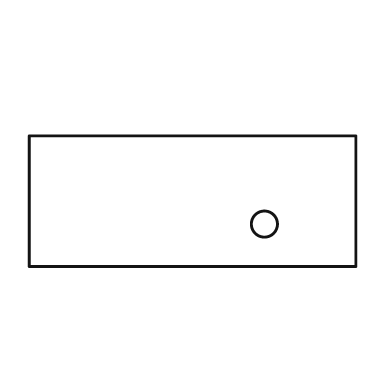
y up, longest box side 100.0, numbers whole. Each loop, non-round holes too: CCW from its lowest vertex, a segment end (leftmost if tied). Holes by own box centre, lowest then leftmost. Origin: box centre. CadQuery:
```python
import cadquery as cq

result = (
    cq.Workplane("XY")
    .moveTo(-50.0, -20.0)
    .lineTo(50.0, -20.0)
    .lineTo(50.0, 20.0)
    .lineTo(-50.0, 20.0)
    .close()
    .moveTo(22.0, -7.0)
    .circle(4.0)
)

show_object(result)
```